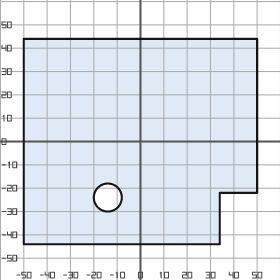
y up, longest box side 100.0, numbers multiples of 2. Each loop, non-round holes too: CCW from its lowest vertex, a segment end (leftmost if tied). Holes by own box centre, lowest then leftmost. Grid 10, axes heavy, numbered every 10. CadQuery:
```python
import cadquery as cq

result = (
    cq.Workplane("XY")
    .moveTo(-50.0, -44.0)
    .lineTo(34.0, -44.0)
    .lineTo(34.0, -22.0)
    .lineTo(50.0, -22.0)
    .lineTo(50.0, 44.0)
    .lineTo(-50.0, 44.0)
    .close()
    .moveTo(-14.0, -24.0)
    .circle(6.0)
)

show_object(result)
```